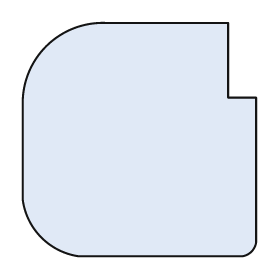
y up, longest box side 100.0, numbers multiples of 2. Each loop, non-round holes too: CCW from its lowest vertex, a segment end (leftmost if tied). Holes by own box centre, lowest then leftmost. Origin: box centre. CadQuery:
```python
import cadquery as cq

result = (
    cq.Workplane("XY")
    .moveTo(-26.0, -50.0)
    .lineTo(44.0, -50.0)
    .threePointArc((48.0, -48.0), (50.0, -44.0))
    .lineTo(50.0, 18.0)
    .lineTo(38.0, 18.0)
    .lineTo(38.0, 50.0)
    .lineTo(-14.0, 50.0)
    .threePointArc((-40.0, 40.0), (-50.0, 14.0))
    .lineTo(-50.0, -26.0)
    .threePointArc((-42.0, -42.0), (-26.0, -50.0))
    .close()
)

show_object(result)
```